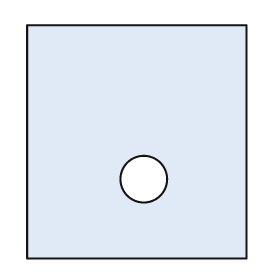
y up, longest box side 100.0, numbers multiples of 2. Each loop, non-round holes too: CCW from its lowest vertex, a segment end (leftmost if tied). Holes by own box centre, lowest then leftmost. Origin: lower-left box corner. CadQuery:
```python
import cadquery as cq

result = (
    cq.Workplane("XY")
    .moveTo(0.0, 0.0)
    .lineTo(94.0, 0.0)
    .lineTo(94.0, 100.0)
    .lineTo(0.0, 100.0)
    .close()
    .moveTo(50.0, 34.0)
    .circle(10.0)
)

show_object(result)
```